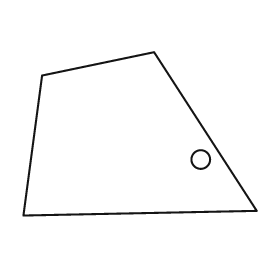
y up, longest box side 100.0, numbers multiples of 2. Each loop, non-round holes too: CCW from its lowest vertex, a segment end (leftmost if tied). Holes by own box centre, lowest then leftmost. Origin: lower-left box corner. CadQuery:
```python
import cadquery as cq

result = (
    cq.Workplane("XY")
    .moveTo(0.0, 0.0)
    .lineTo(100.0, 2.0)
    .lineTo(56.0, 70.0)
    .lineTo(8.0, 60.0)
    .close()
    .moveTo(76.0, 24.0)
    .circle(4.0)
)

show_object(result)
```